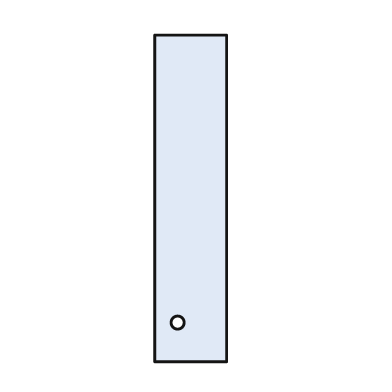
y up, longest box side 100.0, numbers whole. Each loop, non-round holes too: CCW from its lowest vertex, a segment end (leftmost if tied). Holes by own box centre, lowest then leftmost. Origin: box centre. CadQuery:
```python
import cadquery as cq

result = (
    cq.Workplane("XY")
    .moveTo(-11.0, -50.0)
    .lineTo(11.0, -50.0)
    .lineTo(11.0, 50.0)
    .lineTo(-11.0, 50.0)
    .close()
    .moveTo(-4.0, -38.0)
    .circle(2.0)
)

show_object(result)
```